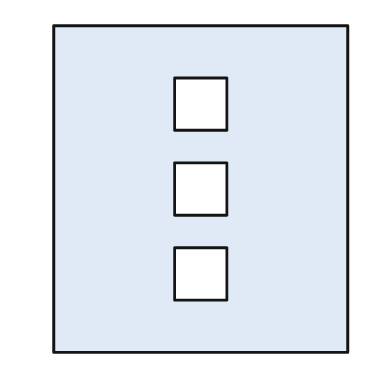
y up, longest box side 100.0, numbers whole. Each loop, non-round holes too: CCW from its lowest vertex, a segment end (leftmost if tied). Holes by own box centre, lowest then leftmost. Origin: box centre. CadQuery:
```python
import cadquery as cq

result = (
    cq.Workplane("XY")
    .moveTo(-45.0, -50.0)
    .lineTo(45.0, -50.0)
    .lineTo(45.0, 50.0)
    .lineTo(-45.0, 50.0)
    .close()
    .moveTo(-8.0, -34.0)
    .lineTo(8.0, -34.0)
    .lineTo(8.0, -18.0)
    .lineTo(-8.0, -18.0)
    .close()
    .moveTo(-8.0, -8.0)
    .lineTo(8.0, -8.0)
    .lineTo(8.0, 8.0)
    .lineTo(-8.0, 8.0)
    .close()
    .moveTo(-8.0, 18.0)
    .lineTo(8.0, 18.0)
    .lineTo(8.0, 34.0)
    .lineTo(-8.0, 34.0)
    .close()
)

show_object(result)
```